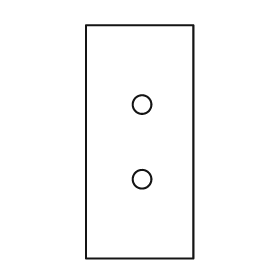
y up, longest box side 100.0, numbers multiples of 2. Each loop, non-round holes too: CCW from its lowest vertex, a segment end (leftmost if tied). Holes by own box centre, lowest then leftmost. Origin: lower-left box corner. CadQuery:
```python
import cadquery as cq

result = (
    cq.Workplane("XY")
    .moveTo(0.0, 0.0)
    .lineTo(46.0, 0.0)
    .lineTo(46.0, 100.0)
    .lineTo(0.0, 100.0)
    .close()
    .moveTo(24.0, 34.0)
    .circle(4.0)
    .moveTo(24.0, 66.0)
    .circle(4.0)
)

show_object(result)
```